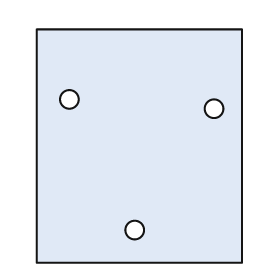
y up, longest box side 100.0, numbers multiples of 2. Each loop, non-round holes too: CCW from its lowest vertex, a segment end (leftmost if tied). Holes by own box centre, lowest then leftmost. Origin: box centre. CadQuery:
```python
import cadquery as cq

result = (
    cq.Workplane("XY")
    .moveTo(-44.0, -50.0)
    .lineTo(44.0, -50.0)
    .lineTo(44.0, 50.0)
    .lineTo(-44.0, 50.0)
    .close()
    .moveTo(-2.0, -36.0)
    .circle(4.0)
    .moveTo(32.0, 16.0)
    .circle(4.0)
    .moveTo(-30.0, 20.0)
    .circle(4.0)
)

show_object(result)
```